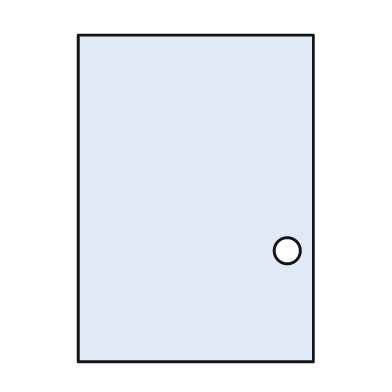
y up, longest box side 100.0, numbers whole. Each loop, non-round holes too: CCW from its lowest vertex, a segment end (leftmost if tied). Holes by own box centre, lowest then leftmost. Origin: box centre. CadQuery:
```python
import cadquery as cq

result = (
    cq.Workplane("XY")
    .moveTo(-36.0, -50.0)
    .lineTo(36.0, -50.0)
    .lineTo(36.0, 50.0)
    .lineTo(-36.0, 50.0)
    .close()
    .moveTo(28.0, -16.0)
    .circle(4.0)
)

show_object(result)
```